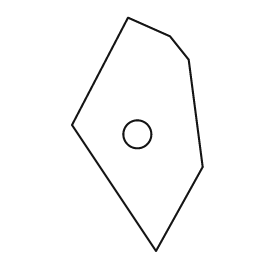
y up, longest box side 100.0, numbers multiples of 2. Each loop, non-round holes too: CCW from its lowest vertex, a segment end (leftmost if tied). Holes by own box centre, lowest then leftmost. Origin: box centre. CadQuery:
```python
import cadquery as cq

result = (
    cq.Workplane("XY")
    .moveTo(8.0, -50.0)
    .lineTo(28.0, -14.0)
    .lineTo(22.0, 32.0)
    .lineTo(14.0, 42.0)
    .lineTo(-4.0, 50.0)
    .lineTo(-28.0, 4.0)
    .close()
    .moveTo(0.0, 0.0)
    .circle(6.0)
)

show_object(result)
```